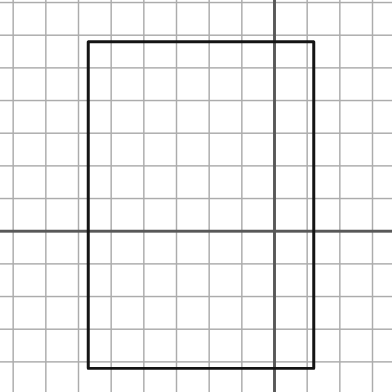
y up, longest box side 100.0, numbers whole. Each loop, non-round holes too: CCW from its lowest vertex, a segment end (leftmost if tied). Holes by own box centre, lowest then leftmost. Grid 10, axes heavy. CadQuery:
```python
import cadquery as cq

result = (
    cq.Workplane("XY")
    .moveTo(-57.0, -42.0)
    .lineTo(12.0, -42.0)
    .lineTo(12.0, 58.0)
    .lineTo(-57.0, 58.0)
    .close()
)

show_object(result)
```